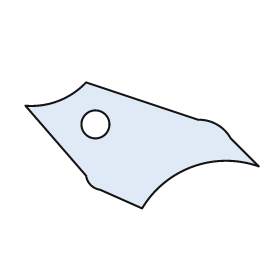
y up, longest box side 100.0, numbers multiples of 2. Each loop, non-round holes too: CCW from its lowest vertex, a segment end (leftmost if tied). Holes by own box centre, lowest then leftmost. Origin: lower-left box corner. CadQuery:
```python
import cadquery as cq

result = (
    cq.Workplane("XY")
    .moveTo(50.0, 0.0)
    .threePointArc((72.0, 18.0), (100.0, 18.0))
    .lineTo(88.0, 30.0)
    .threePointArc((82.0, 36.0), (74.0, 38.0))
    .lineTo(26.0, 54.0)
    .threePointArc((14.0, 46.0), (0.0, 44.0))
    .lineTo(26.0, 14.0)
    .threePointArc((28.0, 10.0), (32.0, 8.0))
    .close()
    .moveTo(30.0, 36.0)
    .circle(6.0)
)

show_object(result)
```